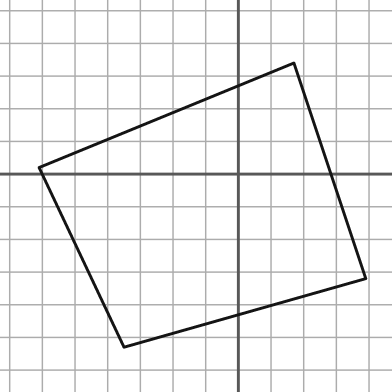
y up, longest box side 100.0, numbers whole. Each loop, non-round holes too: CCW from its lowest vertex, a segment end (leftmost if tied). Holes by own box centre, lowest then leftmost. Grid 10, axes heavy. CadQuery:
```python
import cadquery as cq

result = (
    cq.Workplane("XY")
    .moveTo(-35.0, -53.0)
    .lineTo(39.0, -32.0)
    .lineTo(17.0, 34.0)
    .lineTo(-61.0, 2.0)
    .close()
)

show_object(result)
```